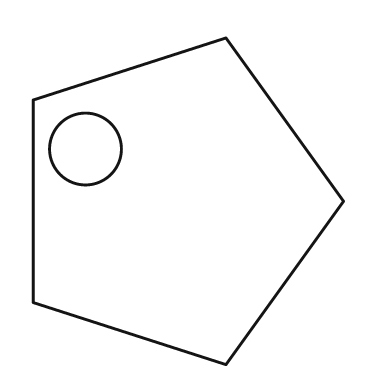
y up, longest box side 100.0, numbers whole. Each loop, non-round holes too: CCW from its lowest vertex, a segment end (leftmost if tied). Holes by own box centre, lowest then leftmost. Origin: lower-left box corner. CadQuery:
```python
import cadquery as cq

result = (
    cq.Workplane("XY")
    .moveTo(59.0, 0.0)
    .lineTo(95.0, 50.0)
    .lineTo(59.0, 100.0)
    .lineTo(0.0, 81.0)
    .lineTo(0.0, 19.0)
    .close()
    .moveTo(16.0, 66.0)
    .circle(11.0)
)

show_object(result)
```